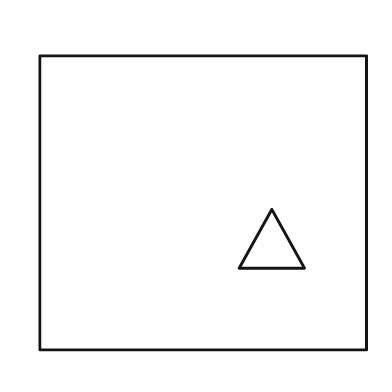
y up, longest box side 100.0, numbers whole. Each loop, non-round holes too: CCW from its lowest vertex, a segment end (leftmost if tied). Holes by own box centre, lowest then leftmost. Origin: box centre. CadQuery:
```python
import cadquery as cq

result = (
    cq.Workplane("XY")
    .moveTo(-50.0, -45.0)
    .lineTo(50.0, -45.0)
    .lineTo(50.0, 45.0)
    .lineTo(-50.0, 45.0)
    .close()
    .moveTo(11.0, -20.0)
    .lineTo(31.0, -20.0)
    .lineTo(21.0, -2.0)
    .close()
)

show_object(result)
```